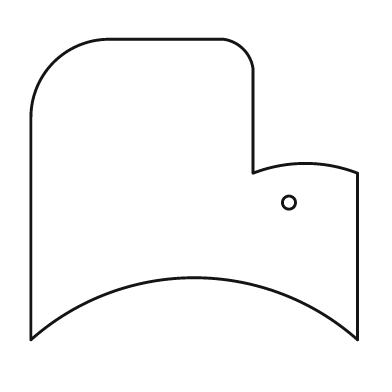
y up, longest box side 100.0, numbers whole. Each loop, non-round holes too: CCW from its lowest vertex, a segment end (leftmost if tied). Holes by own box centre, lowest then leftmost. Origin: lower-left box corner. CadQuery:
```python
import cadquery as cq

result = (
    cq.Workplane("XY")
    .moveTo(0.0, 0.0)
    .threePointArc((50.0, 19.0), (100.0, 0.0))
    .lineTo(100.0, 51.0)
    .threePointArc((84.0, 54.0), (68.0, 51.0))
    .lineTo(68.0, 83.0)
    .threePointArc((65.0, 89.0), (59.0, 92.0))
    .lineTo(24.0, 92.0)
    .threePointArc((7.0, 85.0), (0.0, 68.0))
    .close()
    .moveTo(79.0, 42.0)
    .circle(2.0)
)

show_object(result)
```